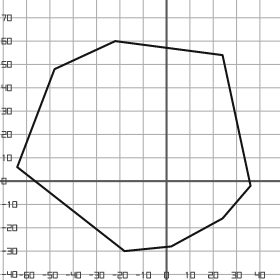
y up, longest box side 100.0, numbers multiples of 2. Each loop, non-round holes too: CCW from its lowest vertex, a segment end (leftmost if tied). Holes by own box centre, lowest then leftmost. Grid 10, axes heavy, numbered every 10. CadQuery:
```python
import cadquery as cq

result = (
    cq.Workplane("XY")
    .moveTo(-18.0, -30.0)
    .lineTo(2.0, -28.0)
    .lineTo(24.0, -16.0)
    .lineTo(36.0, -2.0)
    .lineTo(24.0, 54.0)
    .lineTo(-22.0, 60.0)
    .lineTo(-48.0, 48.0)
    .lineTo(-64.0, 6.0)
    .close()
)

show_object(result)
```